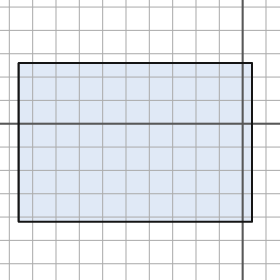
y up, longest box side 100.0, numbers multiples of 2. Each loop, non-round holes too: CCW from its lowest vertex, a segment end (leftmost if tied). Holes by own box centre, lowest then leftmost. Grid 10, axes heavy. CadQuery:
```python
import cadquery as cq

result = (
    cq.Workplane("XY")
    .moveTo(-96.0, -42.0)
    .lineTo(4.0, -42.0)
    .lineTo(4.0, 26.0)
    .lineTo(-96.0, 26.0)
    .close()
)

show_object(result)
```